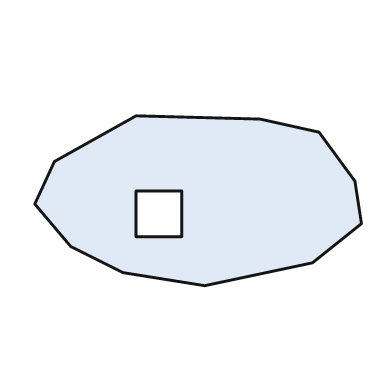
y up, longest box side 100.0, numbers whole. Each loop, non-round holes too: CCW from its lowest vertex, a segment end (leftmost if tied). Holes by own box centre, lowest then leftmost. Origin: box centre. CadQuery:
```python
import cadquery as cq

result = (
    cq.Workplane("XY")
    .moveTo(2.0, -26.0)
    .lineTo(35.0, -19.0)
    .lineTo(50.0, -7.0)
    .lineTo(48.0, 6.0)
    .lineTo(37.0, 21.0)
    .lineTo(19.0, 25.0)
    .lineTo(-19.0, 26.0)
    .lineTo(-44.0, 12.0)
    .lineTo(-50.0, -1.0)
    .lineTo(-39.0, -14.0)
    .lineTo(-23.0, -22.0)
    .close()
    .moveTo(-19.0, -11.0)
    .lineTo(-5.0, -11.0)
    .lineTo(-5.0, 3.0)
    .lineTo(-19.0, 3.0)
    .close()
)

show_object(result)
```